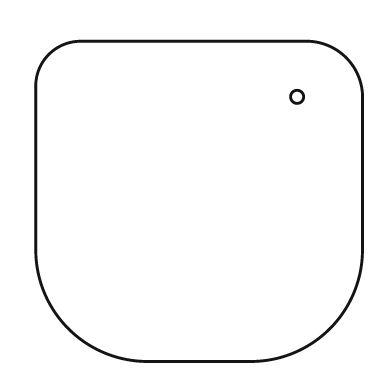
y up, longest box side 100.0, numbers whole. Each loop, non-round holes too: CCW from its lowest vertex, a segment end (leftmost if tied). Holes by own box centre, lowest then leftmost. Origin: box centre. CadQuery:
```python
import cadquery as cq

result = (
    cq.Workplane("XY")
    .moveTo(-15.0, -49.0)
    .lineTo(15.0, -49.0)
    .threePointArc((40.0, -39.0), (50.0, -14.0))
    .lineTo(50.0, 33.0)
    .threePointArc((45.0, 44.0), (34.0, 49.0))
    .lineTo(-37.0, 49.0)
    .threePointArc((-46.0, 45.0), (-50.0, 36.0))
    .lineTo(-50.0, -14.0)
    .threePointArc((-40.0, -39.0), (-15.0, -49.0))
    .close()
    .moveTo(30.0, 32.0)
    .circle(2.0)
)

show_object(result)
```